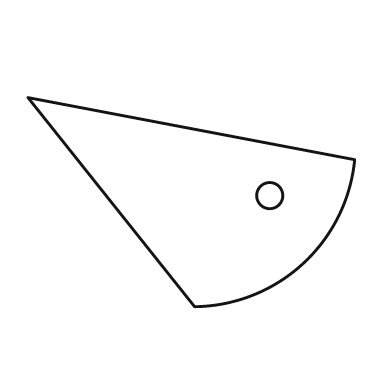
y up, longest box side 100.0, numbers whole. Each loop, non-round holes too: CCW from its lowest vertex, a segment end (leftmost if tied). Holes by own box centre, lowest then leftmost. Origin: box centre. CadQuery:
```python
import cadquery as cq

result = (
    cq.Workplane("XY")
    .moveTo(1.0, -32.0)
    .threePointArc((34.0, -19.0), (50.0, 13.0))
    .lineTo(-50.0, 32.0)
    .close()
    .moveTo(24.0, 2.0)
    .circle(4.0)
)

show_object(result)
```